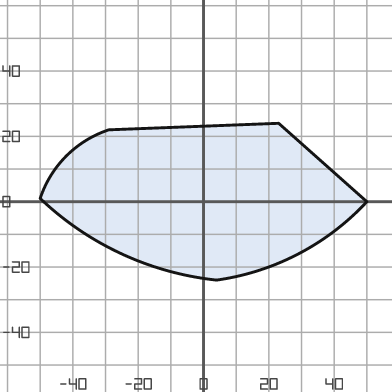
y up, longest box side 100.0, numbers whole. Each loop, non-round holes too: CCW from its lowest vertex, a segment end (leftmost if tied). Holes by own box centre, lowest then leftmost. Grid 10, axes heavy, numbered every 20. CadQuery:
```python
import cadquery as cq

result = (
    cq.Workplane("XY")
    .moveTo(4.0, -24.0)
    .threePointArc((29.0, -16.0), (50.0, 0.0))
    .lineTo(23.0, 24.0)
    .lineTo(-29.0, 22.0)
    .threePointArc((-42.0, 14.0), (-50.0, 1.0))
    .threePointArc((-25.0, -16.0), (4.0, -24.0))
    .close()
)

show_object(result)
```